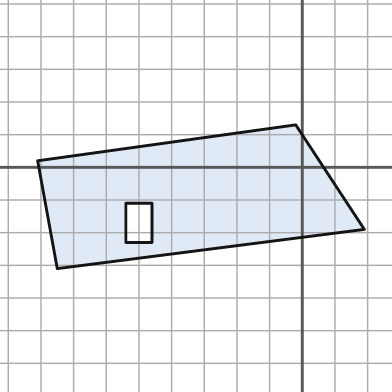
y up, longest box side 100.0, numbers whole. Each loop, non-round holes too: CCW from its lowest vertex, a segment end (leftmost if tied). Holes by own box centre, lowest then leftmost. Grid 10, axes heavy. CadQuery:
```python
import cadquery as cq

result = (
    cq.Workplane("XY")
    .moveTo(-75.0, -31.0)
    .lineTo(19.0, -19.0)
    .lineTo(-2.0, 13.0)
    .lineTo(-81.0, 2.0)
    .close()
    .moveTo(-54.0, -23.0)
    .lineTo(-46.0, -23.0)
    .lineTo(-46.0, -11.0)
    .lineTo(-54.0, -11.0)
    .close()
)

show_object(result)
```